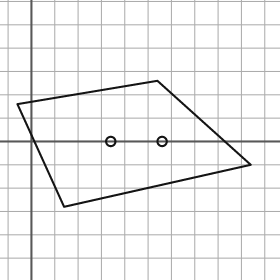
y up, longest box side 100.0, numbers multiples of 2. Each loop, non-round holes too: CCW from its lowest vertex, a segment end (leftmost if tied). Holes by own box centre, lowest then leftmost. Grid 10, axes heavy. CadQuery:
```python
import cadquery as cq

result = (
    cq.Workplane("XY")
    .moveTo(14.0, -28.0)
    .lineTo(94.0, -10.0)
    .lineTo(54.0, 26.0)
    .lineTo(-6.0, 16.0)
    .close()
    .moveTo(34.0, 0.0)
    .circle(2.0)
    .moveTo(56.0, 0.0)
    .circle(2.0)
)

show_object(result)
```